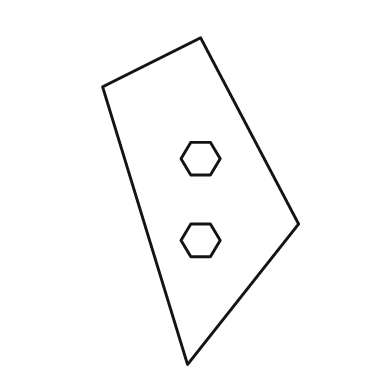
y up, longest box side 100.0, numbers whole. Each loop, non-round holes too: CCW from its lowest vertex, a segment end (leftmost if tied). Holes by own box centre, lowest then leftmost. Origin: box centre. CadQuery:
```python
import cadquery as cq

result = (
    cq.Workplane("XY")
    .moveTo(-4.0, -50.0)
    .lineTo(30.0, -7.0)
    .lineTo(0.0, 50.0)
    .lineTo(-30.0, 35.0)
    .close()
    .moveTo(-3.0, -17.0)
    .lineTo(3.0, -17.0)
    .lineTo(6.0, -12.0)
    .lineTo(3.0, -7.0)
    .lineTo(-3.0, -7.0)
    .lineTo(-6.0, -12.0)
    .close()
    .moveTo(-3.0, 8.0)
    .lineTo(3.0, 8.0)
    .lineTo(6.0, 13.0)
    .lineTo(3.0, 18.0)
    .lineTo(-3.0, 18.0)
    .lineTo(-6.0, 13.0)
    .close()
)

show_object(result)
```